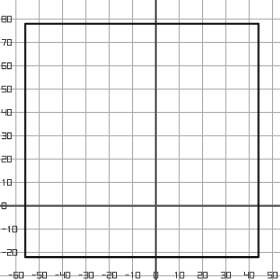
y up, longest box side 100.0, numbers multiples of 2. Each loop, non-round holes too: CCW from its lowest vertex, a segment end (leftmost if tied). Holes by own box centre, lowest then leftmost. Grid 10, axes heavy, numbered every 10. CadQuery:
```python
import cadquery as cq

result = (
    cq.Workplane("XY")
    .moveTo(-56.0, -22.0)
    .lineTo(44.0, -22.0)
    .lineTo(44.0, 78.0)
    .lineTo(-56.0, 78.0)
    .close()
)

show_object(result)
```